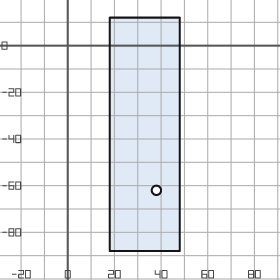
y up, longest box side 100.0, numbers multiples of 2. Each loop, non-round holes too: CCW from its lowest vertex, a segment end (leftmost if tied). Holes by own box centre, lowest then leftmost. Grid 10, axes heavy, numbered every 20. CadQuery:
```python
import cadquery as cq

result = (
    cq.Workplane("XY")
    .moveTo(18.0, -88.0)
    .lineTo(48.0, -88.0)
    .lineTo(48.0, 12.0)
    .lineTo(18.0, 12.0)
    .close()
    .moveTo(38.0, -62.0)
    .circle(2.0)
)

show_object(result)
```